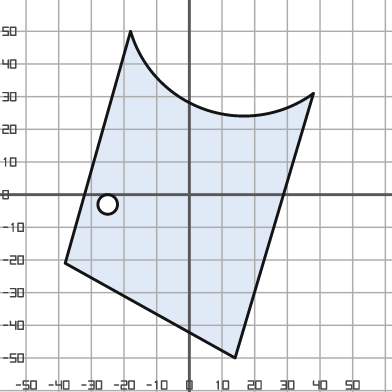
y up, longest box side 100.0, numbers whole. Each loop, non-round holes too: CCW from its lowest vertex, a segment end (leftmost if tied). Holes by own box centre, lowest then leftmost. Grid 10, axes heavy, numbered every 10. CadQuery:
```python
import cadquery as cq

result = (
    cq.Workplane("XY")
    .moveTo(14.0, -50.0)
    .lineTo(38.0, 31.0)
    .threePointArc((5.0, 26.0), (-18.0, 50.0))
    .lineTo(-38.0, -21.0)
    .close()
    .moveTo(-25.0, -3.0)
    .circle(3.0)
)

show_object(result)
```